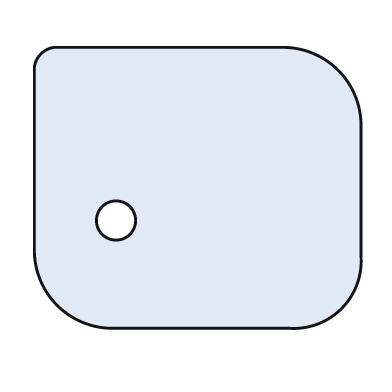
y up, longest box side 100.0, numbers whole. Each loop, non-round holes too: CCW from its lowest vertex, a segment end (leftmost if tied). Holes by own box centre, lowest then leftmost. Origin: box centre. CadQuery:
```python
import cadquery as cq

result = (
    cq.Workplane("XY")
    .moveTo(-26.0, -43.0)
    .lineTo(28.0, -43.0)
    .threePointArc((44.0, -37.0), (50.0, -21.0))
    .lineTo(50.0, 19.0)
    .threePointArc((43.0, 36.0), (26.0, 43.0))
    .lineTo(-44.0, 43.0)
    .threePointArc((-48.0, 41.0), (-50.0, 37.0))
    .lineTo(-50.0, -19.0)
    .threePointArc((-43.0, -36.0), (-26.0, -43.0))
    .close()
    .moveTo(-25.0, -10.0)
    .circle(6.0)
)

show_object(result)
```